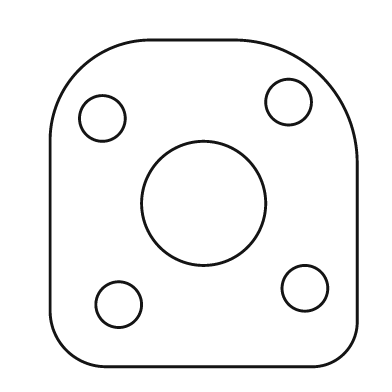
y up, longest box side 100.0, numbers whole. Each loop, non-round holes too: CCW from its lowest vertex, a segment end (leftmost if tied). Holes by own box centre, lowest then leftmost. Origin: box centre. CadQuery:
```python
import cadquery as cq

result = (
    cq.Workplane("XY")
    .moveTo(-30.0, -50.0)
    .lineTo(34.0, -50.0)
    .threePointArc((43.0, -46.0), (47.0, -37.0))
    .lineTo(47.0, 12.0)
    .threePointArc((36.0, 39.0), (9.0, 50.0))
    .lineTo(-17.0, 50.0)
    .threePointArc((-38.0, 41.0), (-47.0, 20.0))
    .lineTo(-47.0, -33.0)
    .threePointArc((-42.0, -45.0), (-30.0, -50.0))
    .close()
    .moveTo(-26.0, -31.0)
    .circle(7.0)
    .moveTo(31.0, -26.0)
    .circle(7.0)
    .moveTo(0.0, 0.0)
    .circle(19.0)
    .moveTo(-31.0, 26.0)
    .circle(7.0)
    .moveTo(26.0, 31.0)
    .circle(7.0)
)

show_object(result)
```